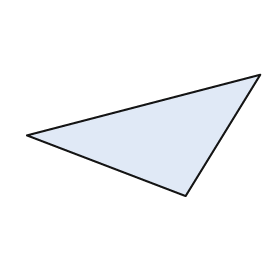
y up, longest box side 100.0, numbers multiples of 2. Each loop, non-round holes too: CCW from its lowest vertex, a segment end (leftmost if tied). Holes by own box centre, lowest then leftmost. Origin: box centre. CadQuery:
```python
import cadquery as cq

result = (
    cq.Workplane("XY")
    .moveTo(18.0, -26.0)
    .lineTo(50.0, 26.0)
    .lineTo(-50.0, 0.0)
    .close()
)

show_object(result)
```